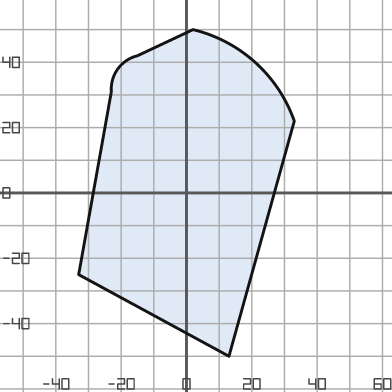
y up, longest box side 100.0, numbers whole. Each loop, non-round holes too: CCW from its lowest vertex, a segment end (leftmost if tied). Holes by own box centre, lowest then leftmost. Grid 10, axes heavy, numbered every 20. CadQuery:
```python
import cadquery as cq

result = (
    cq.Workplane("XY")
    .moveTo(13.0, -50.0)
    .lineTo(33.0, 22.0)
    .threePointArc((21.0, 40.0), (2.0, 50.0))
    .lineTo(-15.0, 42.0)
    .threePointArc((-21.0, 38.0), (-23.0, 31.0))
    .lineTo(-33.0, -25.0)
    .close()
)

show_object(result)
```